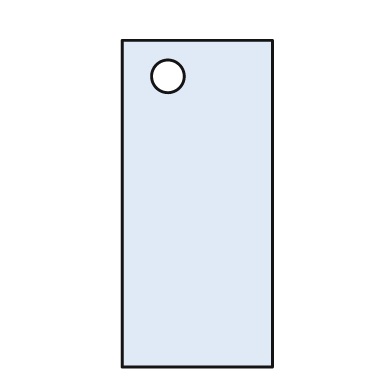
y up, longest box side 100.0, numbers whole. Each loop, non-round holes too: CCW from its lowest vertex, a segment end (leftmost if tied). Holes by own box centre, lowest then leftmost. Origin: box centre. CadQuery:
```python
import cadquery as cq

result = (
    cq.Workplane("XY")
    .moveTo(-23.0, -50.0)
    .lineTo(23.0, -50.0)
    .lineTo(23.0, 50.0)
    .lineTo(-23.0, 50.0)
    .close()
    .moveTo(-9.0, 39.0)
    .circle(5.0)
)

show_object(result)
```